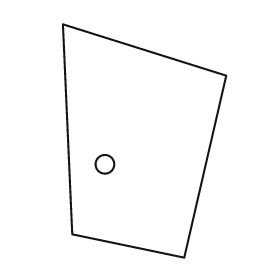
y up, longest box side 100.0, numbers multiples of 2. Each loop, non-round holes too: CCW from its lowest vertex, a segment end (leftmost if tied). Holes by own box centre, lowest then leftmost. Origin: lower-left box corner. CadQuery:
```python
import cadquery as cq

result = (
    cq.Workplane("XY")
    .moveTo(52.0, 0.0)
    .lineTo(70.0, 78.0)
    .lineTo(0.0, 100.0)
    .lineTo(4.0, 10.0)
    .close()
    .moveTo(18.0, 40.0)
    .circle(4.0)
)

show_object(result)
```